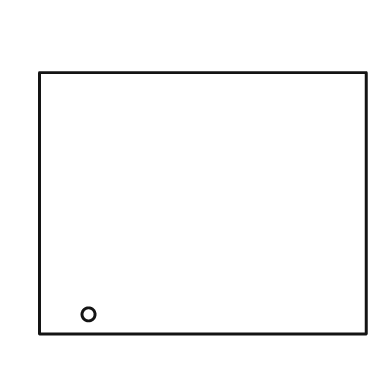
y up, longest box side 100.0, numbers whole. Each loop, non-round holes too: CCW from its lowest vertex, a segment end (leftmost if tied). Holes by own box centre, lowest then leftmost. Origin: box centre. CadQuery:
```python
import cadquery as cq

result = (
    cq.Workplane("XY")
    .moveTo(-50.0, -40.0)
    .lineTo(50.0, -40.0)
    .lineTo(50.0, 40.0)
    .lineTo(-50.0, 40.0)
    .close()
    .moveTo(-35.0, -34.0)
    .circle(2.0)
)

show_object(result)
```